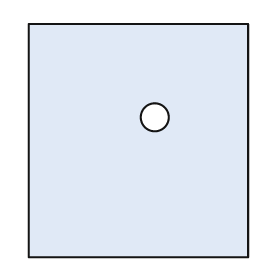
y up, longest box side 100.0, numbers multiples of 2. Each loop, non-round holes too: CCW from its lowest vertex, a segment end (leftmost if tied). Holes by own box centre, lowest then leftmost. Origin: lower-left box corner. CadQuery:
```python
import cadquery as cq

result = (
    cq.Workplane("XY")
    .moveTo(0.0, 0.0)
    .lineTo(94.0, 0.0)
    .lineTo(94.0, 100.0)
    .lineTo(0.0, 100.0)
    .close()
    .moveTo(54.0, 60.0)
    .circle(6.0)
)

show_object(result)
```